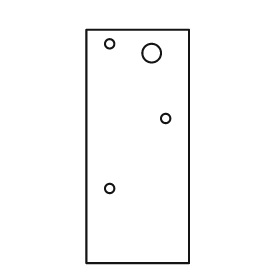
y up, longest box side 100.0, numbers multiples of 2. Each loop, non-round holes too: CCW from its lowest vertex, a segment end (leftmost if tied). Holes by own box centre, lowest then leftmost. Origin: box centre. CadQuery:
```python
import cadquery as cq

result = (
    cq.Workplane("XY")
    .moveTo(-22.0, -50.0)
    .lineTo(22.0, -50.0)
    .lineTo(22.0, 50.0)
    .lineTo(-22.0, 50.0)
    .close()
    .moveTo(-12.0, -18.0)
    .circle(2.0)
    .moveTo(12.0, 12.0)
    .circle(2.0)
    .moveTo(6.0, 40.0)
    .circle(4.0)
    .moveTo(-12.0, 44.0)
    .circle(2.0)
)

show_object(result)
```